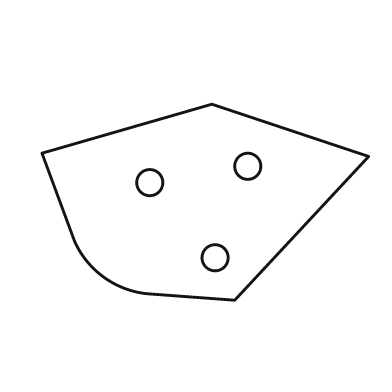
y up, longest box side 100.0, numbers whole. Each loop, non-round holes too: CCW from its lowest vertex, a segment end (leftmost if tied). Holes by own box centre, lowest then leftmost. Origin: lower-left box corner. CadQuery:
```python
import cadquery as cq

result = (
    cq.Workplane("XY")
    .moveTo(59.0, 0.0)
    .lineTo(100.0, 44.0)
    .lineTo(52.0, 60.0)
    .lineTo(0.0, 45.0)
    .lineTo(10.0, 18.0)
    .threePointArc((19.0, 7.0), (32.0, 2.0))
    .close()
    .moveTo(53.0, 13.0)
    .circle(4.0)
    .moveTo(33.0, 36.0)
    .circle(4.0)
    .moveTo(63.0, 41.0)
    .circle(4.0)
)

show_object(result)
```